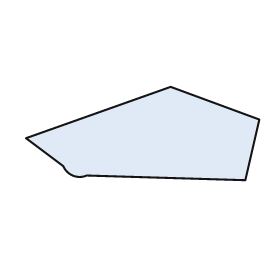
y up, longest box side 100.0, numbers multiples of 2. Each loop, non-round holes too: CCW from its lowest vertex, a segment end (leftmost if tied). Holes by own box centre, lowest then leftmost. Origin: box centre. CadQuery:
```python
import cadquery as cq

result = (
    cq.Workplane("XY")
    .moveTo(44.0, -20.0)
    .lineTo(50.0, 6.0)
    .lineTo(12.0, 20.0)
    .lineTo(-50.0, -2.0)
    .lineTo(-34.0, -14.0)
    .threePointArc((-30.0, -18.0), (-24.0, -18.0))
    .close()
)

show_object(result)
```